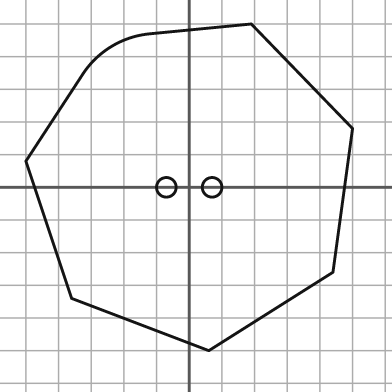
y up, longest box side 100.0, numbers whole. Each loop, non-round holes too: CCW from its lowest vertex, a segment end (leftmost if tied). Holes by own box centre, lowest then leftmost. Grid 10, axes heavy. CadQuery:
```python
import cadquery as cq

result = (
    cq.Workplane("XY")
    .moveTo(6.0, -50.0)
    .lineTo(44.0, -26.0)
    .lineTo(50.0, 18.0)
    .lineTo(19.0, 50.0)
    .lineTo(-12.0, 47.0)
    .threePointArc((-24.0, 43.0), (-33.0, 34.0))
    .lineTo(-50.0, 8.0)
    .lineTo(-36.0, -34.0)
    .close()
    .moveTo(-7.0, 0.0)
    .circle(3.0)
    .moveTo(7.0, 0.0)
    .circle(3.0)
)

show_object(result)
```